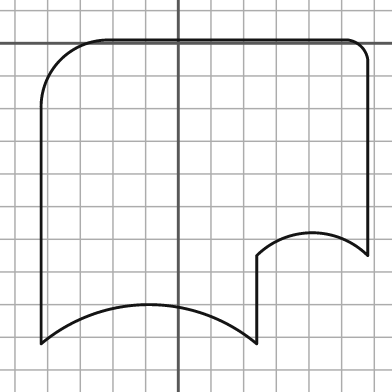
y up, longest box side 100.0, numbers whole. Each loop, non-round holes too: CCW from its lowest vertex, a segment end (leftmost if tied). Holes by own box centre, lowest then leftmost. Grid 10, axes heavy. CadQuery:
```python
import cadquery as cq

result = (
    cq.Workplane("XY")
    .moveTo(-42.0, -92.0)
    .threePointArc((-9.0, -80.0), (24.0, -92.0))
    .lineTo(24.0, -65.0)
    .threePointArc((41.0, -58.0), (58.0, -65.0))
    .lineTo(58.0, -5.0)
    .threePointArc((56.0, -1.0), (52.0, 1.0))
    .lineTo(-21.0, 1.0)
    .threePointArc((-36.0, -5.0), (-42.0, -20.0))
    .close()
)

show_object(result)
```